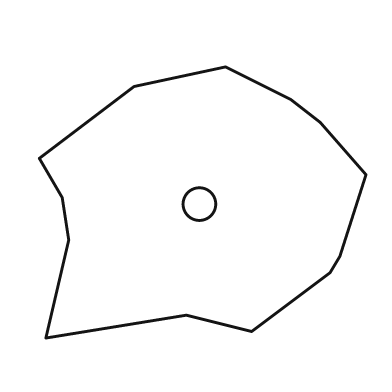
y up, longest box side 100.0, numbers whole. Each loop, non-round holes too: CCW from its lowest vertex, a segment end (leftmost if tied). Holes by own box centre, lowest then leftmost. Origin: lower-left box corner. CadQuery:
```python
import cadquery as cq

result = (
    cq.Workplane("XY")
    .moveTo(2.0, 0.0)
    .lineTo(45.0, 7.0)
    .lineTo(65.0, 2.0)
    .lineTo(89.0, 20.0)
    .lineTo(92.0, 25.0)
    .lineTo(100.0, 50.0)
    .lineTo(86.0, 66.0)
    .lineTo(77.0, 73.0)
    .lineTo(57.0, 83.0)
    .lineTo(29.0, 77.0)
    .lineTo(0.0, 55.0)
    .lineTo(7.0, 43.0)
    .lineTo(9.0, 30.0)
    .close()
    .moveTo(49.0, 41.0)
    .circle(5.0)
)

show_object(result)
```